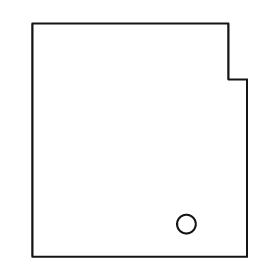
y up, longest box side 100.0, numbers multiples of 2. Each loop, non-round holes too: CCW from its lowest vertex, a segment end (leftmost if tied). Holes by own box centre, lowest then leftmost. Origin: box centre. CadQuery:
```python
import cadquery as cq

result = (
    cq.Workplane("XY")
    .moveTo(-46.0, -50.0)
    .lineTo(46.0, -50.0)
    .lineTo(46.0, 26.0)
    .lineTo(38.0, 26.0)
    .lineTo(38.0, 50.0)
    .lineTo(-46.0, 50.0)
    .close()
    .moveTo(20.0, -36.0)
    .circle(4.0)
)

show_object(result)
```